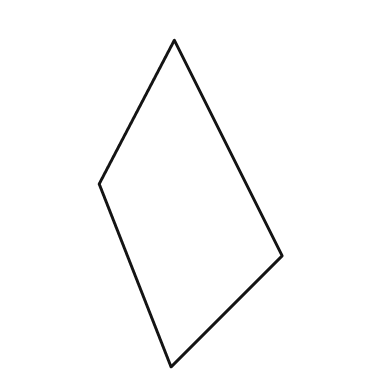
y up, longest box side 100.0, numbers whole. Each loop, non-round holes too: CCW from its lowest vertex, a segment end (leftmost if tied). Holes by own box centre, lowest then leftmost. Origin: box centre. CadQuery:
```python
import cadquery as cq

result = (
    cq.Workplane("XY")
    .moveTo(-6.0, -50.0)
    .lineTo(28.0, -16.0)
    .lineTo(-5.0, 50.0)
    .lineTo(-28.0, 6.0)
    .close()
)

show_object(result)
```